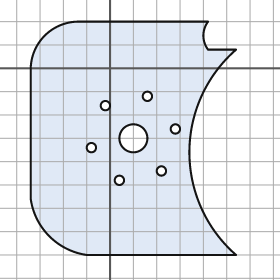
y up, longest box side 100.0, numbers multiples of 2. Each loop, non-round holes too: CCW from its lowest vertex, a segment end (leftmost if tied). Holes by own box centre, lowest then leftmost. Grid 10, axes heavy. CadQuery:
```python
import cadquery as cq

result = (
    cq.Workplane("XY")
    .moveTo(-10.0, -80.0)
    .lineTo(54.0, -80.0)
    .threePointArc((34.0, -36.0), (54.0, 8.0))
    .lineTo(42.0, 8.0)
    .threePointArc((40.0, 14.0), (42.0, 20.0))
    .lineTo(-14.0, 20.0)
    .threePointArc((-28.0, 14.0), (-34.0, 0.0))
    .lineTo(-34.0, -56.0)
    .threePointArc((-26.0, -72.0), (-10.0, -80.0))
    .close()
    .moveTo(4.0, -48.0)
    .circle(2.0)
    .moveTo(22.0, -44.0)
    .circle(2.0)
    .moveTo(-8.0, -34.0)
    .circle(2.0)
    .moveTo(10.0, -30.0)
    .circle(6.0)
    .moveTo(28.0, -26.0)
    .circle(2.0)
    .moveTo(-2.0, -16.0)
    .circle(2.0)
    .moveTo(16.0, -12.0)
    .circle(2.0)
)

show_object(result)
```